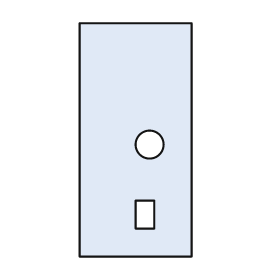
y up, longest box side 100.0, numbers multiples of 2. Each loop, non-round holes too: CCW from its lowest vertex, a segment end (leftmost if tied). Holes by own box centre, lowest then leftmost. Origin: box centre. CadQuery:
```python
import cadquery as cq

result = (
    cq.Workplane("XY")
    .moveTo(-24.0, -50.0)
    .lineTo(24.0, -50.0)
    .lineTo(24.0, 50.0)
    .lineTo(-24.0, 50.0)
    .close()
    .moveTo(0.0, -38.0)
    .lineTo(8.0, -38.0)
    .lineTo(8.0, -26.0)
    .lineTo(0.0, -26.0)
    .close()
    .moveTo(6.0, -2.0)
    .circle(6.0)
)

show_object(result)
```